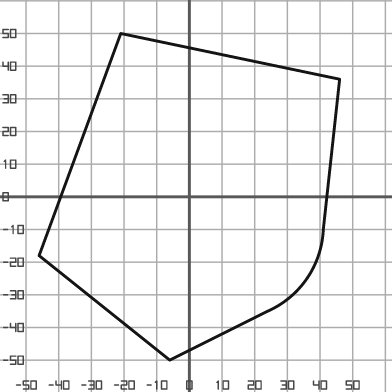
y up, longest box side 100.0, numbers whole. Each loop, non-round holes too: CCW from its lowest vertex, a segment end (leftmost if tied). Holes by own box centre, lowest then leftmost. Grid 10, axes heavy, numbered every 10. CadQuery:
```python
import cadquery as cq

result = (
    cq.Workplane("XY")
    .moveTo(-6.0, -50.0)
    .lineTo(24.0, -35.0)
    .threePointArc((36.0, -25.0), (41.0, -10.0))
    .lineTo(46.0, 36.0)
    .lineTo(-21.0, 50.0)
    .lineTo(-46.0, -18.0)
    .close()
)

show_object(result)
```